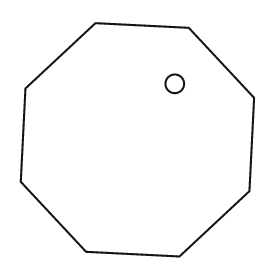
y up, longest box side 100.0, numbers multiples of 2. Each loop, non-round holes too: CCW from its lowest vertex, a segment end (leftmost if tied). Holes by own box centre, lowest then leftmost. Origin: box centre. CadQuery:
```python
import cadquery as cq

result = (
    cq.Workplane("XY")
    .moveTo(18.0, -50.0)
    .lineTo(48.0, -22.0)
    .lineTo(50.0, 18.0)
    .lineTo(22.0, 48.0)
    .lineTo(-18.0, 50.0)
    .lineTo(-48.0, 22.0)
    .lineTo(-50.0, -18.0)
    .lineTo(-22.0, -48.0)
    .close()
    .moveTo(16.0, 24.0)
    .circle(4.0)
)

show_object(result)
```